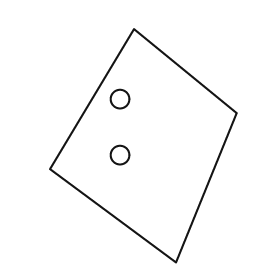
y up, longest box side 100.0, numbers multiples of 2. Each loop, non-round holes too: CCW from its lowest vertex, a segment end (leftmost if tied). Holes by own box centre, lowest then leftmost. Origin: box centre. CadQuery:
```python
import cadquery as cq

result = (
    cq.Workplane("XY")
    .moveTo(14.0, -50.0)
    .lineTo(40.0, 14.0)
    .lineTo(-4.0, 50.0)
    .lineTo(-40.0, -10.0)
    .close()
    .moveTo(-10.0, -4.0)
    .circle(4.0)
    .moveTo(-10.0, 20.0)
    .circle(4.0)
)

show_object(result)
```